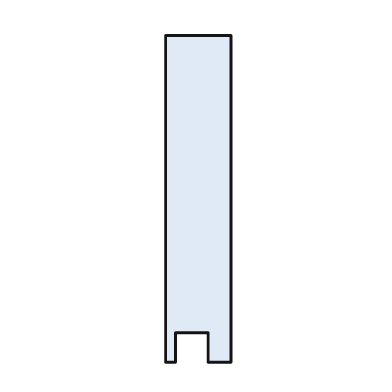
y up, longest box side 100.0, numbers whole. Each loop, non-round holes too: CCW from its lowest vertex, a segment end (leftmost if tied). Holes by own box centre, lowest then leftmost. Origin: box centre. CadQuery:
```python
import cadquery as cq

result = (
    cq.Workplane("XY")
    .moveTo(-10.0, -50.0)
    .lineTo(-7.0, -50.0)
    .lineTo(-7.0, -41.0)
    .lineTo(3.0, -41.0)
    .lineTo(3.0, -50.0)
    .lineTo(10.0, -50.0)
    .lineTo(10.0, 50.0)
    .lineTo(-10.0, 50.0)
    .close()
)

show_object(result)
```